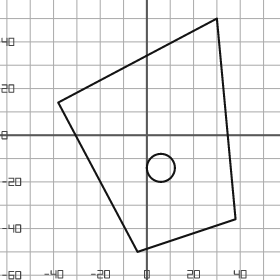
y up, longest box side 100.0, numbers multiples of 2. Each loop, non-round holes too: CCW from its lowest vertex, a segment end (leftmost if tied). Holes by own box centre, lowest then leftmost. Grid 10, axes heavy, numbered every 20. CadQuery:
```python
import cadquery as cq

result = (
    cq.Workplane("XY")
    .moveTo(-4.0, -50.0)
    .lineTo(38.0, -36.0)
    .lineTo(30.0, 50.0)
    .lineTo(-38.0, 14.0)
    .close()
    .moveTo(6.0, -14.0)
    .circle(6.0)
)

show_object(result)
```